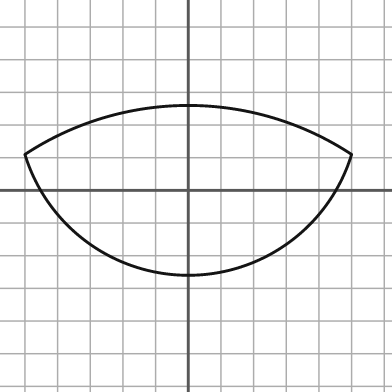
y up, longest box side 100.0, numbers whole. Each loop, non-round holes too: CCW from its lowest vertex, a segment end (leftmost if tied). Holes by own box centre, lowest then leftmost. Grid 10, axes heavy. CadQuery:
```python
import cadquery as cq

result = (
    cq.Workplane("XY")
    .moveTo(-50.0, 11.0)
    .threePointArc((0.0, -26.0), (50.0, 11.0))
    .threePointArc((0.0, 26.0), (-50.0, 11.0))
    .close()
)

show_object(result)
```